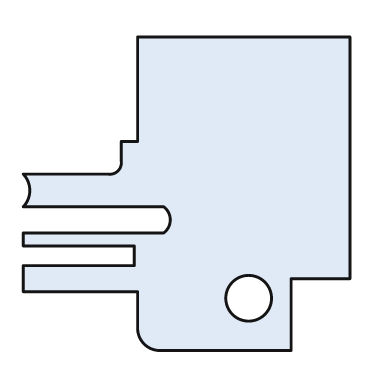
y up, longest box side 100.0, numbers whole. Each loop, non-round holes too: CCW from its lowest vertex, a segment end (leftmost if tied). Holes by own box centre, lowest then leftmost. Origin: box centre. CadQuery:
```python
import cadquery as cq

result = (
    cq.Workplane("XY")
    .moveTo(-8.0, -48.0)
    .lineTo(32.0, -48.0)
    .lineTo(32.0, -26.0)
    .lineTo(50.0, -26.0)
    .lineTo(50.0, 48.0)
    .lineTo(-15.0, 48.0)
    .lineTo(-15.0, 16.0)
    .lineTo(-20.0, 16.0)
    .lineTo(-20.0, 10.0)
    .threePointArc((-21.0, 7.0), (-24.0, 6.0))
    .lineTo(-50.0, 6.0)
    .threePointArc((-48.0, 1.0), (-50.0, -4.0))
    .lineTo(-7.0, -4.0)
    .threePointArc((-5.0, -8.0), (-7.0, -12.0))
    .lineTo(-50.0, -12.0)
    .lineTo(-50.0, -16.0)
    .lineTo(-16.0, -16.0)
    .lineTo(-16.0, -22.0)
    .lineTo(-50.0, -22.0)
    .lineTo(-50.0, -30.0)
    .lineTo(-15.0, -30.0)
    .lineTo(-15.0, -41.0)
    .threePointArc((-13.0, -46.0), (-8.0, -48.0))
    .close()
    .moveTo(19.0, -32.0)
    .circle(7.0)
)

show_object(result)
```